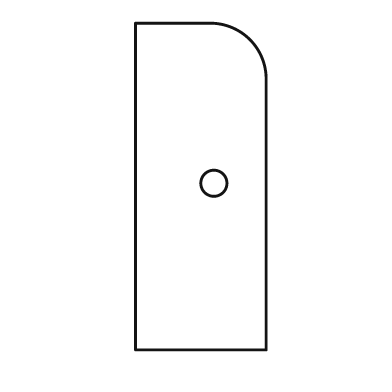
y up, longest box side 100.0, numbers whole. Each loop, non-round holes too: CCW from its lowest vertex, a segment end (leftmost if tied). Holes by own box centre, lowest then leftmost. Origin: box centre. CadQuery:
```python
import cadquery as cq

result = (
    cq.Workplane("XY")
    .moveTo(-20.0, -50.0)
    .lineTo(20.0, -50.0)
    .lineTo(20.0, 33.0)
    .threePointArc((15.0, 45.0), (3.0, 50.0))
    .lineTo(-20.0, 50.0)
    .close()
    .moveTo(4.0, 1.0)
    .circle(4.0)
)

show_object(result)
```